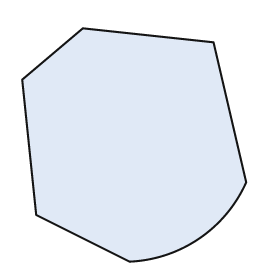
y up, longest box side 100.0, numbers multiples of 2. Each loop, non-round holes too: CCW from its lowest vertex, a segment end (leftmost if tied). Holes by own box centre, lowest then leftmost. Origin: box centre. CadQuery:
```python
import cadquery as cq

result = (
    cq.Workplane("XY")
    .moveTo(-2.0, -50.0)
    .threePointArc((28.0, -40.0), (48.0, -16.0))
    .lineTo(34.0, 44.0)
    .lineTo(-22.0, 50.0)
    .lineTo(-48.0, 28.0)
    .lineTo(-42.0, -30.0)
    .close()
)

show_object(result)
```